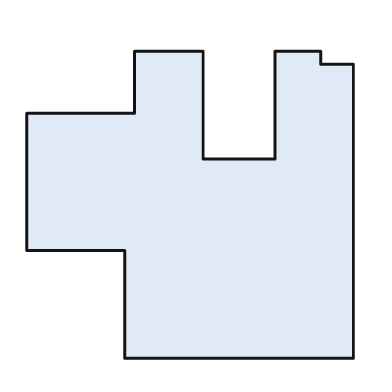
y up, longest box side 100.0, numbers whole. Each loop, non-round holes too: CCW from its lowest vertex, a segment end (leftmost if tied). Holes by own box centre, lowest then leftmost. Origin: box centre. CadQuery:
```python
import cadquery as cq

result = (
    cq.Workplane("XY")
    .moveTo(-20.0, -47.0)
    .lineTo(50.0, -47.0)
    .lineTo(50.0, 43.0)
    .lineTo(40.0, 43.0)
    .lineTo(40.0, 47.0)
    .lineTo(26.0, 47.0)
    .lineTo(26.0, 14.0)
    .lineTo(4.0, 14.0)
    .lineTo(4.0, 47.0)
    .lineTo(-17.0, 47.0)
    .lineTo(-17.0, 28.0)
    .lineTo(-50.0, 28.0)
    .lineTo(-50.0, -14.0)
    .lineTo(-20.0, -14.0)
    .close()
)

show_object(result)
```